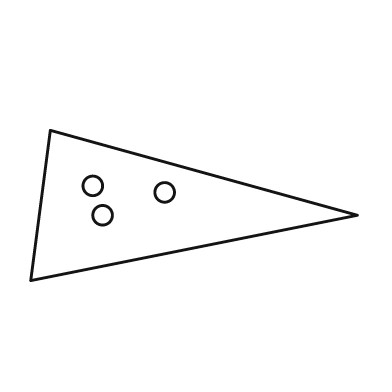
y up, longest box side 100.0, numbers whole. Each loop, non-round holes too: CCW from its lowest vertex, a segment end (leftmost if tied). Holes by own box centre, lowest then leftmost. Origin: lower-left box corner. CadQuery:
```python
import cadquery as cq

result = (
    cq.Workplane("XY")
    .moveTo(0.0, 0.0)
    .lineTo(100.0, 20.0)
    .lineTo(6.0, 46.0)
    .close()
    .moveTo(22.0, 20.0)
    .circle(3.0)
    .moveTo(41.0, 27.0)
    .circle(3.0)
    .moveTo(19.0, 29.0)
    .circle(3.0)
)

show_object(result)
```